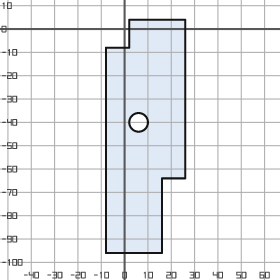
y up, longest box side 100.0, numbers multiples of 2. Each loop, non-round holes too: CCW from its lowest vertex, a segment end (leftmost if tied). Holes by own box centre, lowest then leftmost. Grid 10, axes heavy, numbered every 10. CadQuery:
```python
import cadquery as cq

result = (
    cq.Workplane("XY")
    .moveTo(-8.0, -96.0)
    .lineTo(16.0, -96.0)
    .lineTo(16.0, -64.0)
    .lineTo(26.0, -64.0)
    .lineTo(26.0, 4.0)
    .lineTo(2.0, 4.0)
    .lineTo(2.0, -8.0)
    .lineTo(-8.0, -8.0)
    .close()
    .moveTo(6.0, -40.0)
    .circle(4.0)
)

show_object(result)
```